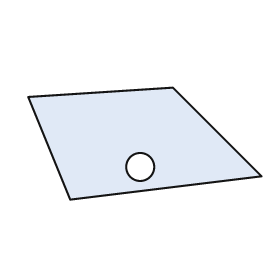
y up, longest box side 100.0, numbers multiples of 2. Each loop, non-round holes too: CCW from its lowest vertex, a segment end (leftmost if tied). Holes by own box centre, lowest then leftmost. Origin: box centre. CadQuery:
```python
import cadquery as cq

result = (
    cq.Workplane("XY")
    .moveTo(-32.0, -24.0)
    .lineTo(50.0, -14.0)
    .lineTo(12.0, 24.0)
    .lineTo(-50.0, 20.0)
    .close()
    .moveTo(-2.0, -10.0)
    .circle(6.0)
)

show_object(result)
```